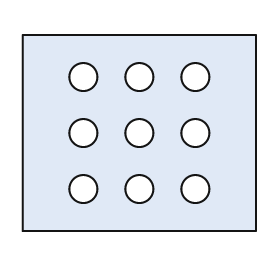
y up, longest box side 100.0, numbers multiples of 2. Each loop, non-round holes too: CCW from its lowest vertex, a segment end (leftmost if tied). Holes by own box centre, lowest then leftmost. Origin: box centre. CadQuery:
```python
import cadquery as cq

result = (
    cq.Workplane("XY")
    .moveTo(-50.0, -42.0)
    .lineTo(50.0, -42.0)
    .lineTo(50.0, 42.0)
    .lineTo(-50.0, 42.0)
    .close()
    .moveTo(-24.0, -24.0)
    .circle(6.0)
    .moveTo(0.0, -24.0)
    .circle(6.0)
    .moveTo(24.0, -24.0)
    .circle(6.0)
    .moveTo(-24.0, 0.0)
    .circle(6.0)
    .moveTo(0.0, 0.0)
    .circle(6.0)
    .moveTo(24.0, 0.0)
    .circle(6.0)
    .moveTo(-24.0, 24.0)
    .circle(6.0)
    .moveTo(0.0, 24.0)
    .circle(6.0)
    .moveTo(24.0, 24.0)
    .circle(6.0)
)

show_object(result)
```